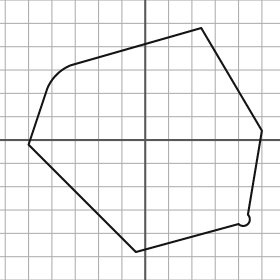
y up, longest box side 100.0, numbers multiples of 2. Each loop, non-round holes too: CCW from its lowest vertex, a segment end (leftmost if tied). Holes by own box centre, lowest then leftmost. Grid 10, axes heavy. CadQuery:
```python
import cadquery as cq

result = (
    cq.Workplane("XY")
    .moveTo(-4.0, -48.0)
    .lineTo(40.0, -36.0)
    .threePointArc((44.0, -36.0), (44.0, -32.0))
    .lineTo(50.0, 4.0)
    .lineTo(24.0, 48.0)
    .lineTo(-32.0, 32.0)
    .threePointArc((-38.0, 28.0), (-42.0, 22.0))
    .lineTo(-50.0, -2.0)
    .close()
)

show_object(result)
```